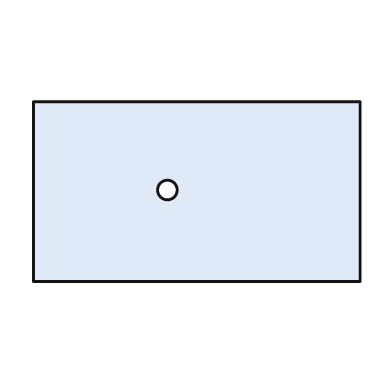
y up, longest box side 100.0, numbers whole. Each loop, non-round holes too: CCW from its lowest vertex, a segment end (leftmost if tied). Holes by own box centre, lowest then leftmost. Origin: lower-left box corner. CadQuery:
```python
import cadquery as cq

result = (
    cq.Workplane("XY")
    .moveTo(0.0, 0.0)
    .lineTo(100.0, 0.0)
    .lineTo(100.0, 55.0)
    .lineTo(0.0, 55.0)
    .close()
    .moveTo(41.0, 28.0)
    .circle(3.0)
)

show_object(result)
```